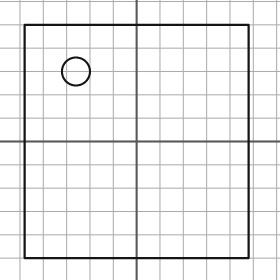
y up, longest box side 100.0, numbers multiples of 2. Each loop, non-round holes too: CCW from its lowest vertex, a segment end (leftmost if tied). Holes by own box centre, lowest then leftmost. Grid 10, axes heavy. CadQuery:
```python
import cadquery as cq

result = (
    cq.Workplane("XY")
    .moveTo(-48.0, -50.0)
    .lineTo(48.0, -50.0)
    .lineTo(48.0, 50.0)
    .lineTo(-48.0, 50.0)
    .close()
    .moveTo(-26.0, 30.0)
    .circle(6.0)
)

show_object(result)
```